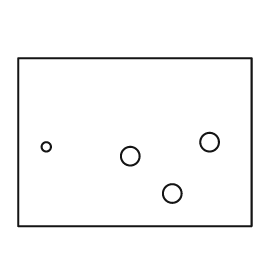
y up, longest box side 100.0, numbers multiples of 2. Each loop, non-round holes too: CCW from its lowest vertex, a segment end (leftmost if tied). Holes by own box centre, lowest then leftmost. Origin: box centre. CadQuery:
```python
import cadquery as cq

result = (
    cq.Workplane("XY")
    .moveTo(-50.0, -36.0)
    .lineTo(50.0, -36.0)
    .lineTo(50.0, 36.0)
    .lineTo(-50.0, 36.0)
    .close()
    .moveTo(16.0, -22.0)
    .circle(4.0)
    .moveTo(-2.0, -6.0)
    .circle(4.0)
    .moveTo(-38.0, -2.0)
    .circle(2.0)
    .moveTo(32.0, 0.0)
    .circle(4.0)
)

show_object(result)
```